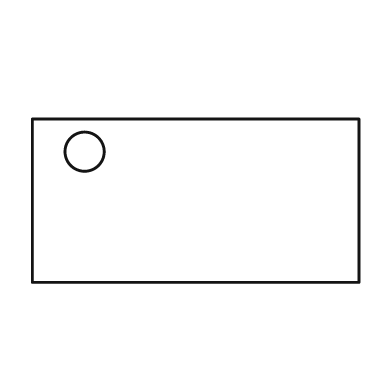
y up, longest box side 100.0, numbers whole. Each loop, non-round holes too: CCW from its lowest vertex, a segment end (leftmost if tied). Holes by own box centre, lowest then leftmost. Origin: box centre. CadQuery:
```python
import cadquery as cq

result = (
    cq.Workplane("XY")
    .moveTo(-50.0, -25.0)
    .lineTo(50.0, -25.0)
    .lineTo(50.0, 25.0)
    .lineTo(-50.0, 25.0)
    .close()
    .moveTo(-34.0, 15.0)
    .circle(6.0)
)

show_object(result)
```